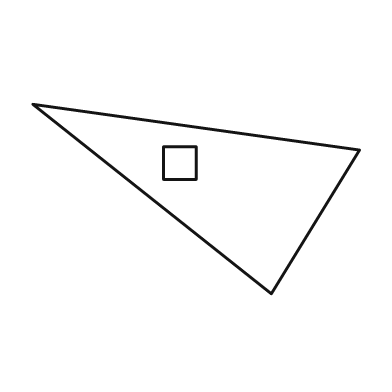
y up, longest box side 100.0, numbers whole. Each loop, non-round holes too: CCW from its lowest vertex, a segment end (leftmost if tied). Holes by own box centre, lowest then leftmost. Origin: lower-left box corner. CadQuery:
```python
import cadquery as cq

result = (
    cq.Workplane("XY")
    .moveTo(73.0, 0.0)
    .lineTo(100.0, 44.0)
    .lineTo(0.0, 58.0)
    .close()
    .moveTo(40.0, 35.0)
    .lineTo(50.0, 35.0)
    .lineTo(50.0, 45.0)
    .lineTo(40.0, 45.0)
    .close()
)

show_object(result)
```